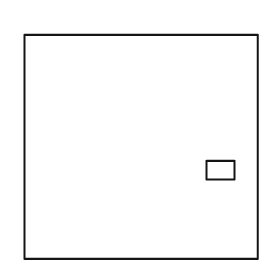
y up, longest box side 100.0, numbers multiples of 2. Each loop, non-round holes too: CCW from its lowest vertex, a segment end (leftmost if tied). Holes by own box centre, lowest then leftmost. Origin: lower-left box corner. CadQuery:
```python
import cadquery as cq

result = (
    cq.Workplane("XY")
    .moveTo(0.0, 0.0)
    .lineTo(100.0, 0.0)
    .lineTo(100.0, 96.0)
    .lineTo(0.0, 96.0)
    .close()
    .moveTo(78.0, 34.0)
    .lineTo(90.0, 34.0)
    .lineTo(90.0, 42.0)
    .lineTo(78.0, 42.0)
    .close()
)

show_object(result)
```